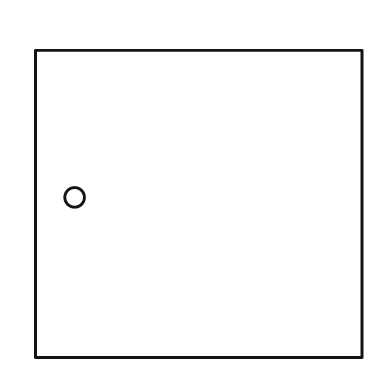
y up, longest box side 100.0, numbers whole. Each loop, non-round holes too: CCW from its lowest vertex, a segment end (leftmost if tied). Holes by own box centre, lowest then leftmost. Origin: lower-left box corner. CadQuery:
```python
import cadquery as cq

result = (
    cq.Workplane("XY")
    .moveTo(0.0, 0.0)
    .lineTo(100.0, 0.0)
    .lineTo(100.0, 94.0)
    .lineTo(0.0, 94.0)
    .close()
    .moveTo(12.0, 49.0)
    .circle(3.0)
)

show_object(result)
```